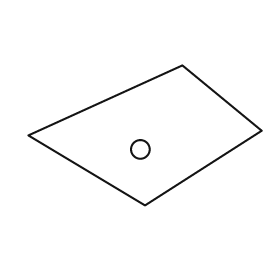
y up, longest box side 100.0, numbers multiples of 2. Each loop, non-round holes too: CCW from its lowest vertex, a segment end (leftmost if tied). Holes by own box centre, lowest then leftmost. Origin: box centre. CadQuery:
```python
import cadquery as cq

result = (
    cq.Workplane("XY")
    .moveTo(0.0, -30.0)
    .lineTo(50.0, 2.0)
    .lineTo(16.0, 30.0)
    .lineTo(-50.0, 0.0)
    .close()
    .moveTo(-2.0, -6.0)
    .circle(4.0)
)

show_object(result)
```